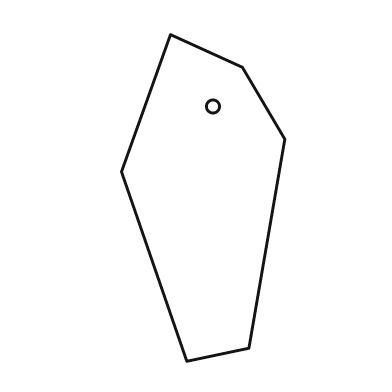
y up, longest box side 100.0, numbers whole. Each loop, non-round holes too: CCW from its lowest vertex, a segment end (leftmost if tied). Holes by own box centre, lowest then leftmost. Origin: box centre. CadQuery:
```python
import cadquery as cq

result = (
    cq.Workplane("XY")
    .moveTo(-5.0, -50.0)
    .lineTo(14.0, -46.0)
    .lineTo(25.0, 18.0)
    .lineTo(12.0, 40.0)
    .lineTo(-10.0, 50.0)
    .lineTo(-25.0, 8.0)
    .close()
    .moveTo(3.0, 28.0)
    .circle(2.0)
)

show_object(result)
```